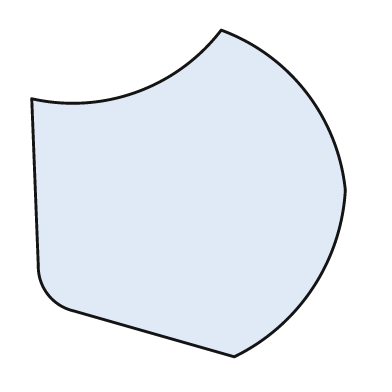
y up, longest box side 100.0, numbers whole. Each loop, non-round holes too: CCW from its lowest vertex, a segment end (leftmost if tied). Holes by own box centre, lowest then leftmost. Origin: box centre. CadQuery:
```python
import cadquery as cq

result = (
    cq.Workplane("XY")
    .moveTo(14.0, -50.0)
    .threePointArc((38.0, -29.0), (48.0, 1.0))
    .threePointArc((36.0, 31.0), (10.0, 50.0))
    .threePointArc((-16.0, 31.0), (-48.0, 29.0))
    .lineTo(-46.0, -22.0)
    .threePointArc((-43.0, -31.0), (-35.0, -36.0))
    .close()
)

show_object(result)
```